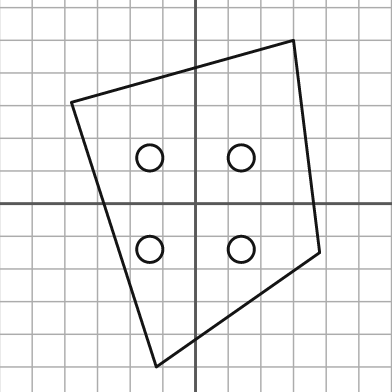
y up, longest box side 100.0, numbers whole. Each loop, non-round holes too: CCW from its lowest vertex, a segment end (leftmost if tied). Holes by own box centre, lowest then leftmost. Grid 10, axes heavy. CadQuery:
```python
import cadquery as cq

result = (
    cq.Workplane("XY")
    .moveTo(-12.0, -50.0)
    .lineTo(38.0, -15.0)
    .lineTo(30.0, 50.0)
    .lineTo(-38.0, 31.0)
    .close()
    .moveTo(-14.0, -14.0)
    .circle(4.0)
    .moveTo(14.0, -14.0)
    .circle(4.0)
    .moveTo(-14.0, 14.0)
    .circle(4.0)
    .moveTo(14.0, 14.0)
    .circle(4.0)
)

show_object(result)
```